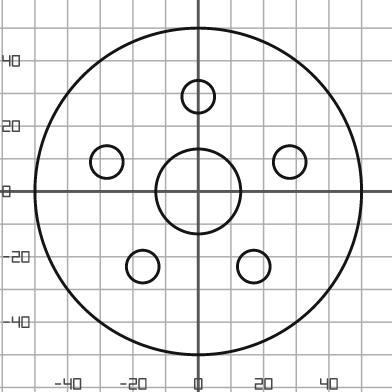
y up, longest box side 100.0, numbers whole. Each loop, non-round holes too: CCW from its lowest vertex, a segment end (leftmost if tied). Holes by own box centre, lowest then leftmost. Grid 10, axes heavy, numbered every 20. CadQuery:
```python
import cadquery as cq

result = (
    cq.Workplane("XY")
    .moveTo(0.0, 0.0)
    .circle(50.0)
    .moveTo(-17.0, -23.0)
    .circle(5.0)
    .moveTo(17.0, -23.0)
    .circle(5.0)
    .moveTo(0.0, 0.0)
    .circle(13.0)
    .moveTo(-28.0, 9.0)
    .circle(5.0)
    .moveTo(28.0, 9.0)
    .circle(5.0)
    .moveTo(0.0, 29.0)
    .circle(5.0)
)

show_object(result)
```